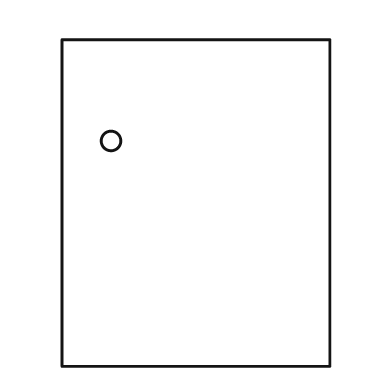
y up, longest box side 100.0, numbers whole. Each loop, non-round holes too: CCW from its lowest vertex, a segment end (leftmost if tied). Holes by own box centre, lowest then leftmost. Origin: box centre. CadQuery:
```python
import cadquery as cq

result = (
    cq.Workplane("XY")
    .moveTo(-41.0, -50.0)
    .lineTo(41.0, -50.0)
    .lineTo(41.0, 50.0)
    .lineTo(-41.0, 50.0)
    .close()
    .moveTo(-26.0, 19.0)
    .circle(3.0)
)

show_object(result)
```